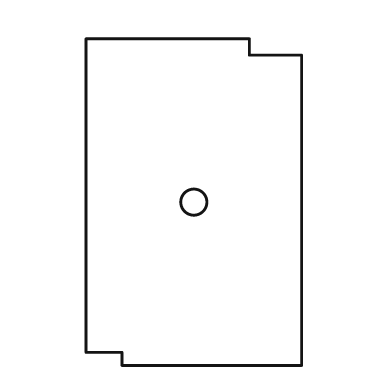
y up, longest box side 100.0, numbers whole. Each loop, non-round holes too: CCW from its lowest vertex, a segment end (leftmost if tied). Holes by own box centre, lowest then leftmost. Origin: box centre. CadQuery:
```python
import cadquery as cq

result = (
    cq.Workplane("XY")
    .moveTo(-22.0, -50.0)
    .lineTo(33.0, -50.0)
    .lineTo(33.0, 45.0)
    .lineTo(17.0, 45.0)
    .lineTo(17.0, 50.0)
    .lineTo(-33.0, 50.0)
    .lineTo(-33.0, -46.0)
    .lineTo(-22.0, -46.0)
    .close()
    .moveTo(0.0, 0.0)
    .circle(4.0)
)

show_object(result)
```